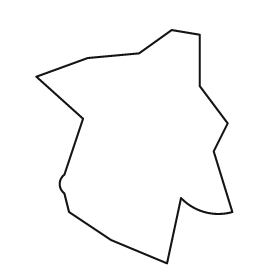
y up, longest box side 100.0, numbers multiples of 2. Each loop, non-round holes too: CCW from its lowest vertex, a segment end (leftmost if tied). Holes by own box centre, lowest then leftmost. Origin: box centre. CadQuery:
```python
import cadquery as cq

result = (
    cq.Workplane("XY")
    .moveTo(14.0, -50.0)
    .lineTo(20.0, -22.0)
    .threePointArc((30.0, -28.0), (42.0, -28.0))
    .lineTo(34.0, -2.0)
    .lineTo(40.0, 10.0)
    .lineTo(28.0, 26.0)
    .lineTo(28.0, 48.0)
    .lineTo(16.0, 50.0)
    .lineTo(2.0, 40.0)
    .lineTo(-20.0, 38.0)
    .lineTo(-42.0, 30.0)
    .lineTo(-22.0, 12.0)
    .lineTo(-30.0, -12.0)
    .threePointArc((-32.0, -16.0), (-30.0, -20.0))
    .lineTo(-28.0, -28.0)
    .lineTo(-10.0, -40.0)
    .close()
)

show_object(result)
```